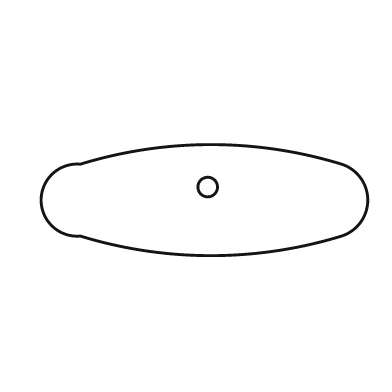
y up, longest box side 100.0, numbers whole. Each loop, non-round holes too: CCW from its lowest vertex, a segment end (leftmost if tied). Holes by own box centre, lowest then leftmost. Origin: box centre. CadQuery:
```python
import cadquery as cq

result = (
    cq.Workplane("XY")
    .moveTo(-38.0, -11.0)
    .threePointArc((2.0, -17.0), (42.0, -11.0))
    .threePointArc((50.0, 0.0), (42.0, 11.0))
    .threePointArc((2.0, 17.0), (-38.0, 11.0))
    .threePointArc((-50.0, 0.0), (-38.0, -11.0))
    .close()
    .moveTo(1.0, 4.0)
    .circle(3.0)
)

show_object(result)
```